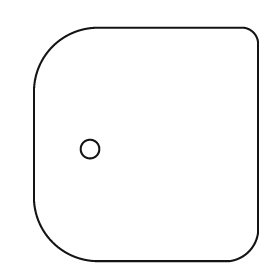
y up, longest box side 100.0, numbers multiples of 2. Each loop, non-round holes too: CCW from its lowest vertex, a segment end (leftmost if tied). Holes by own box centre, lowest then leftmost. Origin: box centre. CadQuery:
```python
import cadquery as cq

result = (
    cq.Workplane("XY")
    .moveTo(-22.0, -50.0)
    .lineTo(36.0, -50.0)
    .threePointArc((44.0, -46.0), (48.0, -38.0))
    .lineTo(48.0, 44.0)
    .threePointArc((46.0, 48.0), (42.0, 50.0))
    .lineTo(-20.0, 50.0)
    .threePointArc((-40.0, 42.0), (-48.0, 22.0))
    .lineTo(-48.0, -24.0)
    .threePointArc((-40.0, -42.0), (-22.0, -50.0))
    .close()
    .moveTo(-24.0, -2.0)
    .circle(4.0)
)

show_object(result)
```